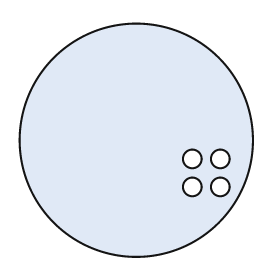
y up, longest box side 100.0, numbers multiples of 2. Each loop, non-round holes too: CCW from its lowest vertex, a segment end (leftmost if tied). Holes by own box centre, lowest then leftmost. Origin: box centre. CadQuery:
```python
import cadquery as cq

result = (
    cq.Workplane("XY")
    .moveTo(0.0, 0.0)
    .circle(50.0)
    .moveTo(24.0, -20.0)
    .circle(4.0)
    .moveTo(36.0, -20.0)
    .circle(4.0)
    .moveTo(24.0, -8.0)
    .circle(4.0)
    .moveTo(36.0, -8.0)
    .circle(4.0)
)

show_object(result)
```